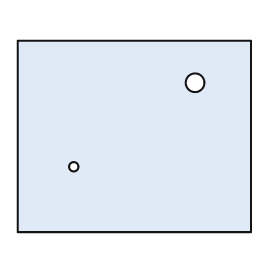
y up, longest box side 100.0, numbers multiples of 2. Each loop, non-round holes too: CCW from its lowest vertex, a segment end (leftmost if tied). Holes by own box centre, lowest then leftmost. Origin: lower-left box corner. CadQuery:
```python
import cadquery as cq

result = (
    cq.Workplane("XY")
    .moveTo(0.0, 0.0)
    .lineTo(100.0, 0.0)
    .lineTo(100.0, 82.0)
    .lineTo(0.0, 82.0)
    .close()
    .moveTo(24.0, 28.0)
    .circle(2.0)
    .moveTo(76.0, 64.0)
    .circle(4.0)
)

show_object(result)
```